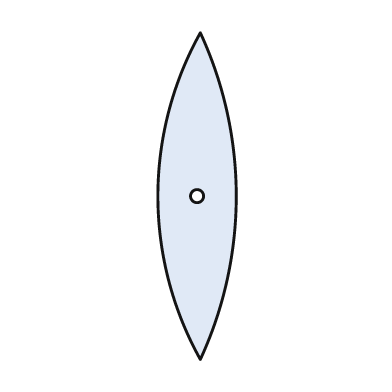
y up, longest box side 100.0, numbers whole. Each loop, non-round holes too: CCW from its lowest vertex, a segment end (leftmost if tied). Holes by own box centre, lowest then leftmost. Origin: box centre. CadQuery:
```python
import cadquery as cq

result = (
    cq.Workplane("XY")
    .moveTo(1.0, -50.0)
    .threePointArc((12.0, 0.0), (1.0, 50.0))
    .threePointArc((-12.0, 0.0), (1.0, -50.0))
    .close()
    .moveTo(0.0, 0.0)
    .circle(2.0)
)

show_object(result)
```